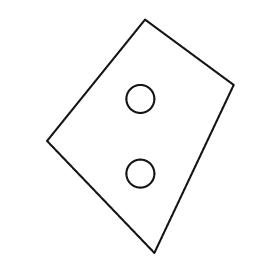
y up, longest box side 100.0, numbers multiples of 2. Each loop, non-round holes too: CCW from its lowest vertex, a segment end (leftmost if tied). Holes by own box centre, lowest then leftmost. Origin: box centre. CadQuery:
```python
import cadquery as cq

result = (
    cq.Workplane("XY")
    .moveTo(6.0, -50.0)
    .lineTo(40.0, 22.0)
    .lineTo(2.0, 50.0)
    .lineTo(-40.0, -2.0)
    .close()
    .moveTo(0.0, -16.0)
    .circle(6.0)
    .moveTo(0.0, 16.0)
    .circle(6.0)
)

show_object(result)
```